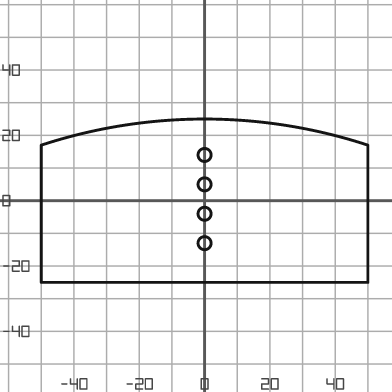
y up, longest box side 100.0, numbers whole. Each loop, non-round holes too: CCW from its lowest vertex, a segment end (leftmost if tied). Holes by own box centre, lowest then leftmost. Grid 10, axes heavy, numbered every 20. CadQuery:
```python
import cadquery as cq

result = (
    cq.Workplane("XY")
    .moveTo(-50.0, -25.0)
    .lineTo(50.0, -25.0)
    .lineTo(50.0, 17.0)
    .threePointArc((0.0, 25.0), (-50.0, 17.0))
    .close()
    .moveTo(0.0, -13.0)
    .circle(2.0)
    .moveTo(0.0, -4.0)
    .circle(2.0)
    .moveTo(0.0, 5.0)
    .circle(2.0)
    .moveTo(0.0, 14.0)
    .circle(2.0)
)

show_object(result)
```